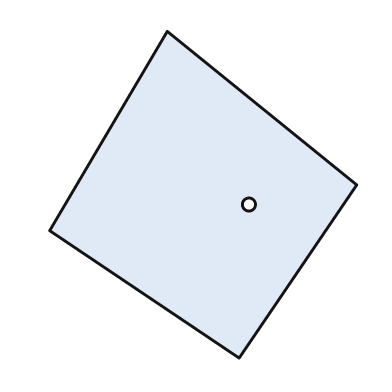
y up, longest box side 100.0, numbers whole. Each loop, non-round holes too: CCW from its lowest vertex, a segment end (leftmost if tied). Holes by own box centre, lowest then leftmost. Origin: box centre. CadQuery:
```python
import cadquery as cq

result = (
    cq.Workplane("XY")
    .moveTo(11.0, -50.0)
    .lineTo(47.0, 3.0)
    .lineTo(-11.0, 50.0)
    .lineTo(-47.0, -11.0)
    .close()
    .moveTo(14.0, -3.0)
    .circle(2.0)
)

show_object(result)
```